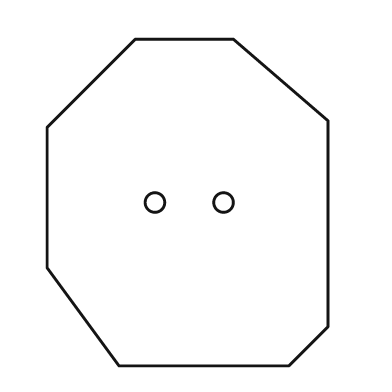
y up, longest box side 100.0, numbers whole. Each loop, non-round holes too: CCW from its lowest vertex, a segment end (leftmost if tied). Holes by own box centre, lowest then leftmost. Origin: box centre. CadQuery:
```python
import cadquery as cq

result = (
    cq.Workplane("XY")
    .moveTo(-21.0, -50.0)
    .lineTo(31.0, -50.0)
    .lineTo(43.0, -38.0)
    .lineTo(43.0, 25.0)
    .lineTo(14.0, 50.0)
    .lineTo(-16.0, 50.0)
    .lineTo(-43.0, 23.0)
    .lineTo(-43.0, -20.0)
    .close()
    .moveTo(-10.0, 0.0)
    .circle(3.0)
    .moveTo(11.0, 0.0)
    .circle(3.0)
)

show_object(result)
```